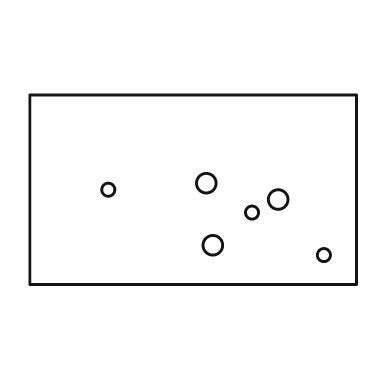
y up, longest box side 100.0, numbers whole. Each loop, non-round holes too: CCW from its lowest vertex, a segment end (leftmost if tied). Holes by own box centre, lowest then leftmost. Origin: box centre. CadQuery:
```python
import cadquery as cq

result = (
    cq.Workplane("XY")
    .moveTo(-50.0, -29.0)
    .lineTo(50.0, -29.0)
    .lineTo(50.0, 29.0)
    .lineTo(-50.0, 29.0)
    .close()
    .moveTo(40.0, -20.0)
    .circle(2.0)
    .moveTo(6.0, -17.0)
    .circle(3.0)
    .moveTo(18.0, -7.0)
    .circle(2.0)
    .moveTo(26.0, -3.0)
    .circle(3.0)
    .moveTo(-26.0, 0.0)
    .circle(2.0)
    .moveTo(4.0, 2.0)
    .circle(3.0)
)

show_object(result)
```